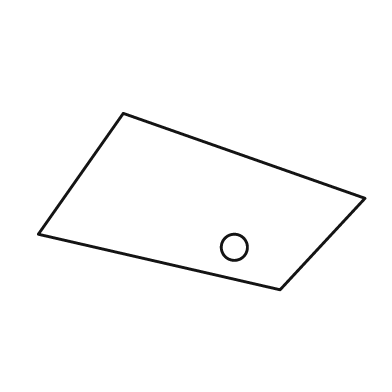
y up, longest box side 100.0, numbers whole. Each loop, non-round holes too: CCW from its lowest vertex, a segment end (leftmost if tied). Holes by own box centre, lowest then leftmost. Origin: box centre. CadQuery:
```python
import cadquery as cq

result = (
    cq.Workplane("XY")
    .moveTo(24.0, -27.0)
    .lineTo(50.0, 1.0)
    .lineTo(-24.0, 27.0)
    .lineTo(-50.0, -10.0)
    .close()
    .moveTo(10.0, -14.0)
    .circle(4.0)
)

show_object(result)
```